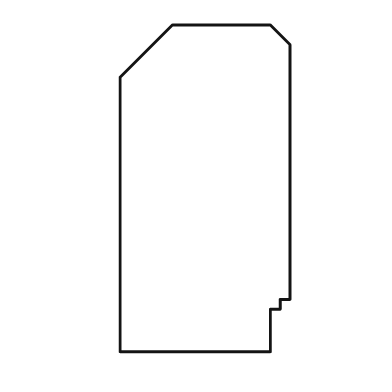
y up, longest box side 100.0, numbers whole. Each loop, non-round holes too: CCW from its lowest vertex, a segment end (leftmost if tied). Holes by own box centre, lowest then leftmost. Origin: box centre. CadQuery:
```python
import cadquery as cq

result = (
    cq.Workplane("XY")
    .moveTo(-26.0, -50.0)
    .lineTo(20.0, -50.0)
    .lineTo(20.0, -37.0)
    .lineTo(23.0, -37.0)
    .lineTo(23.0, -34.0)
    .lineTo(26.0, -34.0)
    .lineTo(26.0, 44.0)
    .lineTo(20.0, 50.0)
    .lineTo(-10.0, 50.0)
    .lineTo(-26.0, 34.0)
    .close()
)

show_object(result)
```